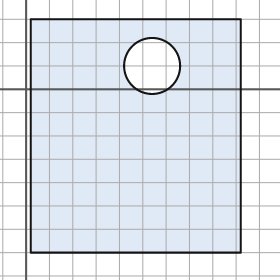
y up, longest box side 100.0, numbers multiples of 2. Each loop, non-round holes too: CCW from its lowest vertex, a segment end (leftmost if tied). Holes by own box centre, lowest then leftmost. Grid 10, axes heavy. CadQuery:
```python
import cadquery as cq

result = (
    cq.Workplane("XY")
    .moveTo(2.0, -70.0)
    .lineTo(92.0, -70.0)
    .lineTo(92.0, 30.0)
    .lineTo(2.0, 30.0)
    .close()
    .moveTo(54.0, 10.0)
    .circle(12.0)
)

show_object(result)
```